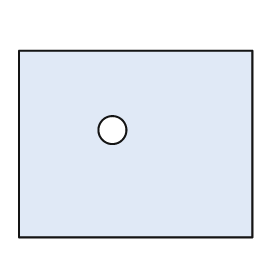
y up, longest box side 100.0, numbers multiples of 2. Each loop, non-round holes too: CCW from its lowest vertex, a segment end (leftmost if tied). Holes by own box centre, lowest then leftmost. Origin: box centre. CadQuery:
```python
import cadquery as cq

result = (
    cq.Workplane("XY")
    .moveTo(-50.0, -40.0)
    .lineTo(50.0, -40.0)
    .lineTo(50.0, 40.0)
    .lineTo(-50.0, 40.0)
    .close()
    .moveTo(-10.0, 6.0)
    .circle(6.0)
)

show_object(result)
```